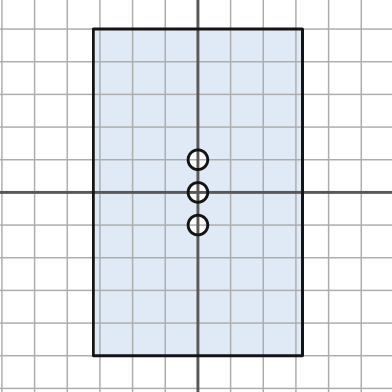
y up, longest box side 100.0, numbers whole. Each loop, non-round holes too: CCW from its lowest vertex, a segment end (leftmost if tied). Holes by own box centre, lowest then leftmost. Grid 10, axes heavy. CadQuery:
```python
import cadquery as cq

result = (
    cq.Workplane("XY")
    .moveTo(-32.0, -50.0)
    .lineTo(32.0, -50.0)
    .lineTo(32.0, 50.0)
    .lineTo(-32.0, 50.0)
    .close()
    .moveTo(0.0, -10.0)
    .circle(3.0)
    .moveTo(0.0, 0.0)
    .circle(3.0)
    .moveTo(0.0, 10.0)
    .circle(3.0)
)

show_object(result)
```